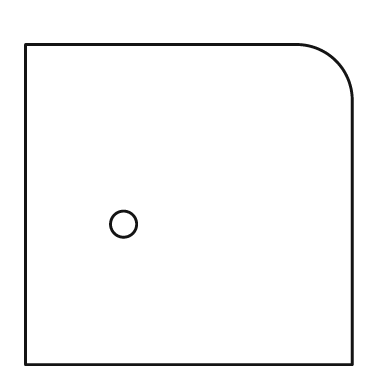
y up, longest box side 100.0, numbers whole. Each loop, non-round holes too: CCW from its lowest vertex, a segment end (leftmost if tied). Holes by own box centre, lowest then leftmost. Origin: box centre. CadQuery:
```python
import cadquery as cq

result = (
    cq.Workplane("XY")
    .moveTo(-50.0, -49.0)
    .lineTo(50.0, -49.0)
    .lineTo(50.0, 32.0)
    .threePointArc((45.0, 44.0), (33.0, 49.0))
    .lineTo(-50.0, 49.0)
    .close()
    .moveTo(-20.0, -6.0)
    .circle(4.0)
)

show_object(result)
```